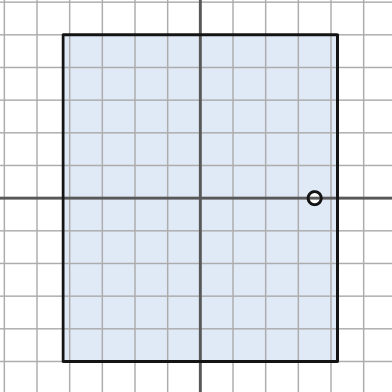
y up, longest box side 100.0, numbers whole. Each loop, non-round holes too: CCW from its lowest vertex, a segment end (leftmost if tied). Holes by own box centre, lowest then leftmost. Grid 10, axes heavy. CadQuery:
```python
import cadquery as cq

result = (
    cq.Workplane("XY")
    .moveTo(-42.0, -50.0)
    .lineTo(42.0, -50.0)
    .lineTo(42.0, 50.0)
    .lineTo(-42.0, 50.0)
    .close()
    .moveTo(35.0, 0.0)
    .circle(2.0)
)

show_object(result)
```